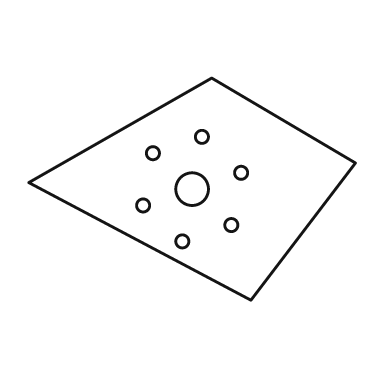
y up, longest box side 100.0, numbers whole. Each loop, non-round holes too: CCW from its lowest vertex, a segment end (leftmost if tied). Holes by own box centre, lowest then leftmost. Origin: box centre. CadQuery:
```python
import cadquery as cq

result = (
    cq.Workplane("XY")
    .moveTo(18.0, -34.0)
    .lineTo(50.0, 8.0)
    .lineTo(6.0, 34.0)
    .lineTo(-50.0, 2.0)
    .close()
    .moveTo(-3.0, -16.0)
    .circle(2.0)
    .moveTo(12.0, -11.0)
    .circle(2.0)
    .moveTo(-15.0, -5.0)
    .circle(2.0)
    .moveTo(0.0, 0.0)
    .circle(5.0)
    .moveTo(15.0, 5.0)
    .circle(2.0)
    .moveTo(-12.0, 11.0)
    .circle(2.0)
    .moveTo(3.0, 16.0)
    .circle(2.0)
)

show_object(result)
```